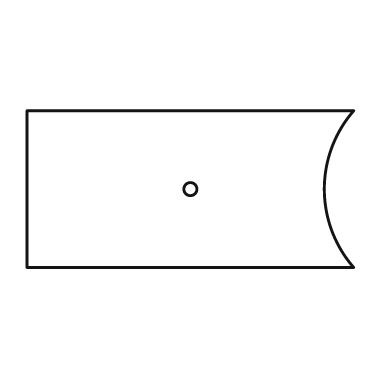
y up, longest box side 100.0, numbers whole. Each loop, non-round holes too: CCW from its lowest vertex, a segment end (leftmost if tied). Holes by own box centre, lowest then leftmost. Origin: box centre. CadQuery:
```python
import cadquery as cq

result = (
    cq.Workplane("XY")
    .moveTo(-50.0, -24.0)
    .lineTo(50.0, -24.0)
    .threePointArc((41.0, 0.0), (50.0, 24.0))
    .lineTo(-50.0, 24.0)
    .close()
    .moveTo(0.0, 0.0)
    .circle(2.0)
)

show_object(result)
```